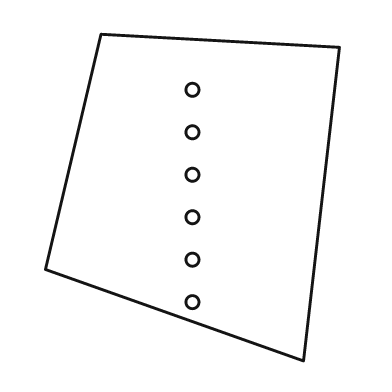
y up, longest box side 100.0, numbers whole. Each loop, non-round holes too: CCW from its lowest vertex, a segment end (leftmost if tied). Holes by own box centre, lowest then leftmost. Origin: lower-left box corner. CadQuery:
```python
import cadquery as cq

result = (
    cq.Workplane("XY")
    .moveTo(79.0, 0.0)
    .lineTo(90.0, 96.0)
    .lineTo(17.0, 100.0)
    .lineTo(0.0, 28.0)
    .close()
    .moveTo(45.0, 18.0)
    .circle(2.0)
    .moveTo(45.0, 31.0)
    .circle(2.0)
    .moveTo(45.0, 44.0)
    .circle(2.0)
    .moveTo(45.0, 57.0)
    .circle(2.0)
    .moveTo(45.0, 70.0)
    .circle(2.0)
    .moveTo(45.0, 83.0)
    .circle(2.0)
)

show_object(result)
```